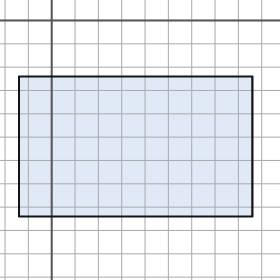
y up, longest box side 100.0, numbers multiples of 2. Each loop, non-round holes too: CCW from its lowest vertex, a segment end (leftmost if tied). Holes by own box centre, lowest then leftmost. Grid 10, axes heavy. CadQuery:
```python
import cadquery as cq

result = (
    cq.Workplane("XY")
    .moveTo(-14.0, -84.0)
    .lineTo(86.0, -84.0)
    .lineTo(86.0, -24.0)
    .lineTo(-14.0, -24.0)
    .close()
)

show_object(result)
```